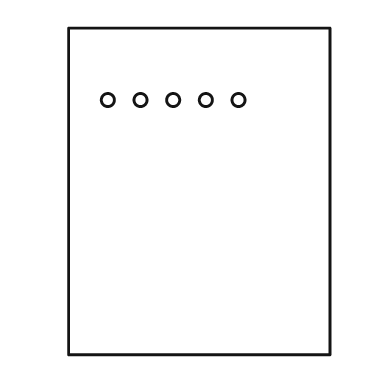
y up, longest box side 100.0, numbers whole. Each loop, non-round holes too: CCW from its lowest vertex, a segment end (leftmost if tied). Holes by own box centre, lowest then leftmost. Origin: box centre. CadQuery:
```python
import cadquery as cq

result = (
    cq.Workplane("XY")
    .moveTo(-40.0, -50.0)
    .lineTo(40.0, -50.0)
    .lineTo(40.0, 50.0)
    .lineTo(-40.0, 50.0)
    .close()
    .moveTo(-28.0, 28.0)
    .circle(2.0)
    .moveTo(-18.0, 28.0)
    .circle(2.0)
    .moveTo(-8.0, 28.0)
    .circle(2.0)
    .moveTo(2.0, 28.0)
    .circle(2.0)
    .moveTo(12.0, 28.0)
    .circle(2.0)
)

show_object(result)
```